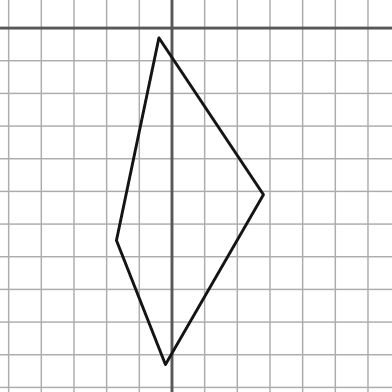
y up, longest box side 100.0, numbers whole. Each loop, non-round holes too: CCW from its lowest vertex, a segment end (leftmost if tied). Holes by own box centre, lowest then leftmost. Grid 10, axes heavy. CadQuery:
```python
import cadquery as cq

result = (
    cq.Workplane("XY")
    .moveTo(-2.0, -103.0)
    .lineTo(28.0, -51.0)
    .lineTo(-4.0, -3.0)
    .lineTo(-17.0, -65.0)
    .close()
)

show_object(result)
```